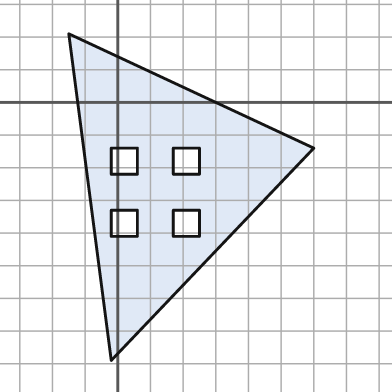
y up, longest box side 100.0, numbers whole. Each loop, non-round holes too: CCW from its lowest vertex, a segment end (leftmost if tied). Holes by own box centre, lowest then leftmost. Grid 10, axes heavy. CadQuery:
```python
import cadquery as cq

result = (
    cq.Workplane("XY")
    .moveTo(-2.0, -79.0)
    .lineTo(60.0, -14.0)
    .lineTo(-15.0, 21.0)
    .close()
    .moveTo(-2.0, -41.0)
    .lineTo(6.0, -41.0)
    .lineTo(6.0, -33.0)
    .lineTo(-2.0, -33.0)
    .close()
    .moveTo(17.0, -41.0)
    .lineTo(25.0, -41.0)
    .lineTo(25.0, -33.0)
    .lineTo(17.0, -33.0)
    .close()
    .moveTo(-2.0, -22.0)
    .lineTo(6.0, -22.0)
    .lineTo(6.0, -14.0)
    .lineTo(-2.0, -14.0)
    .close()
    .moveTo(17.0, -22.0)
    .lineTo(25.0, -22.0)
    .lineTo(25.0, -14.0)
    .lineTo(17.0, -14.0)
    .close()
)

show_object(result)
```